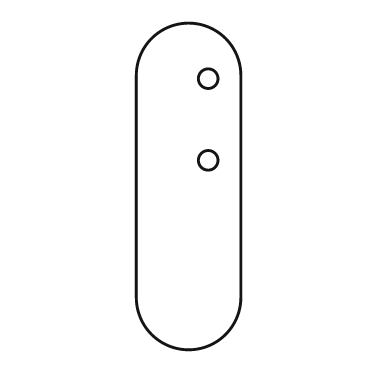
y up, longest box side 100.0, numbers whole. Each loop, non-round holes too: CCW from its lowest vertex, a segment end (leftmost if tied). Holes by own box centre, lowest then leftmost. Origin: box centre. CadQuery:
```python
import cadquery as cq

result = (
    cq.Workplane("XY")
    .moveTo(-16.0, -34.0)
    .threePointArc((0.0, -50.0), (16.0, -34.0))
    .lineTo(16.0, 34.0)
    .threePointArc((0.0, 50.0), (-16.0, 34.0))
    .close()
    .moveTo(6.0, 8.0)
    .circle(3.0)
    .moveTo(6.0, 33.0)
    .circle(3.0)
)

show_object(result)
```